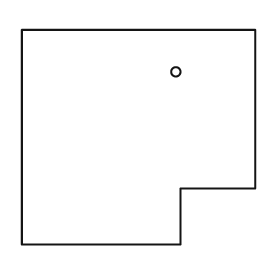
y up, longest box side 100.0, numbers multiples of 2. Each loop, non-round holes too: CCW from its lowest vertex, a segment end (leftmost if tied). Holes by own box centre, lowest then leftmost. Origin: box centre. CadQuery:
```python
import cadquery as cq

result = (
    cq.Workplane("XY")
    .moveTo(-50.0, -46.0)
    .lineTo(18.0, -46.0)
    .lineTo(18.0, -22.0)
    .lineTo(50.0, -22.0)
    .lineTo(50.0, 46.0)
    .lineTo(-50.0, 46.0)
    .close()
    .moveTo(16.0, 28.0)
    .circle(2.0)
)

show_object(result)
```